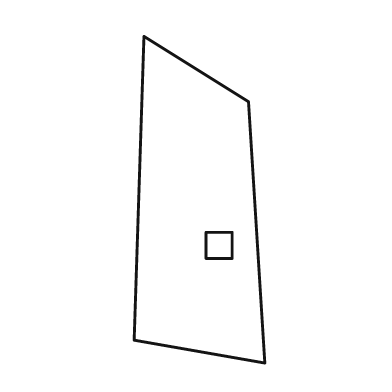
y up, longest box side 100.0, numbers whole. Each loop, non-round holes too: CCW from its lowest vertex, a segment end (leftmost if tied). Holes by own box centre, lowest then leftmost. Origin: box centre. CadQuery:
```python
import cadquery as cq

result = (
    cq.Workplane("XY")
    .moveTo(20.0, -50.0)
    .lineTo(15.0, 30.0)
    .lineTo(-17.0, 50.0)
    .lineTo(-20.0, -43.0)
    .close()
    .moveTo(2.0, -18.0)
    .lineTo(10.0, -18.0)
    .lineTo(10.0, -10.0)
    .lineTo(2.0, -10.0)
    .close()
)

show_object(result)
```